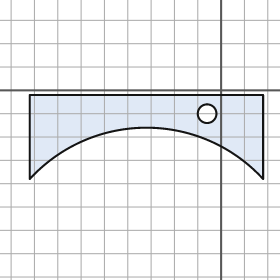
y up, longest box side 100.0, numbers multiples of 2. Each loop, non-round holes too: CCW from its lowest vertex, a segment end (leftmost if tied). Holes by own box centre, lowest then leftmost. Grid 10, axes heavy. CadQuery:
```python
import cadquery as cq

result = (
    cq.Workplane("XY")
    .moveTo(-82.0, -38.0)
    .threePointArc((-32.0, -16.0), (18.0, -38.0))
    .lineTo(18.0, -2.0)
    .lineTo(-82.0, -2.0)
    .close()
    .moveTo(-6.0, -10.0)
    .circle(4.0)
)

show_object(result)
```